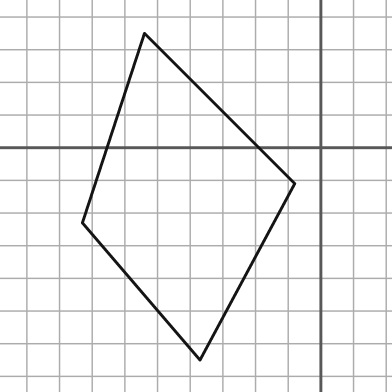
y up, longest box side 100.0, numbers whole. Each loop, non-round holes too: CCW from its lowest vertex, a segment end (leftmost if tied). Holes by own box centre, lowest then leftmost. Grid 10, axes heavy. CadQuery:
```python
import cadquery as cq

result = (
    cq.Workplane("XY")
    .moveTo(-37.0, -65.0)
    .lineTo(-8.0, -11.0)
    .lineTo(-54.0, 35.0)
    .lineTo(-73.0, -23.0)
    .close()
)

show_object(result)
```